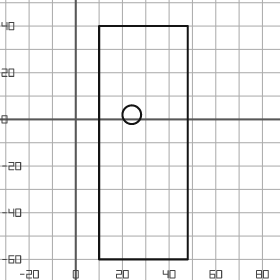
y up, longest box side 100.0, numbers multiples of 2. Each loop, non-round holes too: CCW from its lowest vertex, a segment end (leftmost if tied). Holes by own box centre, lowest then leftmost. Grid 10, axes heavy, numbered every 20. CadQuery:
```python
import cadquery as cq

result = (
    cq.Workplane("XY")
    .moveTo(10.0, -60.0)
    .lineTo(48.0, -60.0)
    .lineTo(48.0, 40.0)
    .lineTo(10.0, 40.0)
    .close()
    .moveTo(24.0, 2.0)
    .circle(4.0)
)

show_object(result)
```